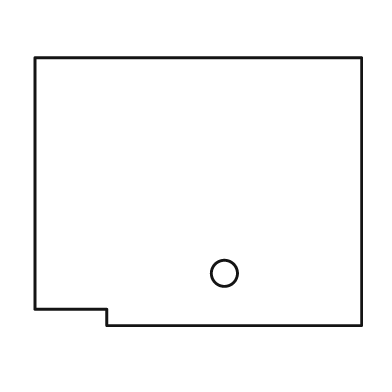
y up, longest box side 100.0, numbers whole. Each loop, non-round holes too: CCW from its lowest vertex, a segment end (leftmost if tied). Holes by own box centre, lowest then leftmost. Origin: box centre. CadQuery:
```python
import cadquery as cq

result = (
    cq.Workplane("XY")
    .moveTo(-28.0, -41.0)
    .lineTo(50.0, -41.0)
    .lineTo(50.0, 41.0)
    .lineTo(-50.0, 41.0)
    .lineTo(-50.0, -36.0)
    .lineTo(-28.0, -36.0)
    .close()
    .moveTo(8.0, -25.0)
    .circle(4.0)
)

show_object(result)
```